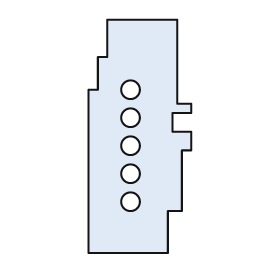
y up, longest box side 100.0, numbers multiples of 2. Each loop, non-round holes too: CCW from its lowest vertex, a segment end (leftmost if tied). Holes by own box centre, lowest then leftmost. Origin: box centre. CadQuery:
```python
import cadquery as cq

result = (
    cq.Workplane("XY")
    .moveTo(-22.0, -50.0)
    .lineTo(12.0, -50.0)
    .lineTo(12.0, -32.0)
    .lineTo(18.0, -32.0)
    .lineTo(18.0, -6.0)
    .lineTo(22.0, -6.0)
    .lineTo(22.0, 2.0)
    .lineTo(14.0, 2.0)
    .lineTo(14.0, 10.0)
    .lineTo(22.0, 10.0)
    .lineTo(22.0, 14.0)
    .lineTo(16.0, 14.0)
    .lineTo(16.0, 50.0)
    .lineTo(-14.0, 50.0)
    .lineTo(-14.0, 34.0)
    .lineTo(-18.0, 34.0)
    .lineTo(-18.0, 20.0)
    .lineTo(-22.0, 20.0)
    .close()
    .moveTo(-4.0, -28.0)
    .circle(4.0)
    .moveTo(-4.0, -16.0)
    .circle(4.0)
    .moveTo(-4.0, -4.0)
    .circle(4.0)
    .moveTo(-4.0, 8.0)
    .circle(4.0)
    .moveTo(-4.0, 20.0)
    .circle(4.0)
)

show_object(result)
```